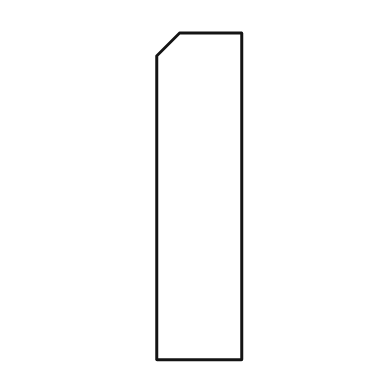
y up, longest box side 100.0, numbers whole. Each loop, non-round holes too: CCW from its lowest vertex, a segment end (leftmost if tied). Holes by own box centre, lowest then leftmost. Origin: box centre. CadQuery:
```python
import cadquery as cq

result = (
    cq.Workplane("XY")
    .moveTo(-13.0, -50.0)
    .lineTo(13.0, -50.0)
    .lineTo(13.0, 50.0)
    .lineTo(-6.0, 50.0)
    .lineTo(-13.0, 43.0)
    .close()
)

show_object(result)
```